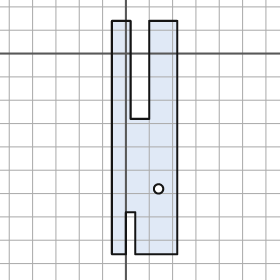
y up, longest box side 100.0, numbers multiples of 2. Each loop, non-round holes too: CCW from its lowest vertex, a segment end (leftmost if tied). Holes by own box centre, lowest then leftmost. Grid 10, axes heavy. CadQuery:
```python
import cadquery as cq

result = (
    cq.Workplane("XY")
    .moveTo(-6.0, -86.0)
    .lineTo(0.0, -86.0)
    .lineTo(0.0, -68.0)
    .lineTo(4.0, -68.0)
    .lineTo(4.0, -86.0)
    .lineTo(22.0, -86.0)
    .lineTo(22.0, 14.0)
    .lineTo(10.0, 14.0)
    .lineTo(10.0, -28.0)
    .lineTo(2.0, -28.0)
    .lineTo(2.0, 14.0)
    .lineTo(-6.0, 14.0)
    .close()
    .moveTo(14.0, -58.0)
    .circle(2.0)
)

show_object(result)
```